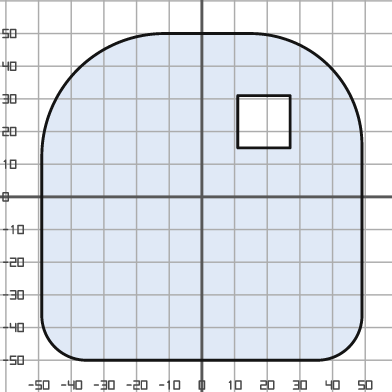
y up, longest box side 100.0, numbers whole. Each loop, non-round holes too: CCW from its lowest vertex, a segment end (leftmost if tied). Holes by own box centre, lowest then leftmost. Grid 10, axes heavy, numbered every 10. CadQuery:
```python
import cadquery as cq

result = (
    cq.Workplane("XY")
    .moveTo(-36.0, -50.0)
    .lineTo(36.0, -50.0)
    .threePointArc((45.0, -46.0), (49.0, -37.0))
    .lineTo(49.0, 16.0)
    .threePointArc((39.0, 40.0), (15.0, 50.0))
    .lineTo(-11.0, 50.0)
    .threePointArc((-38.0, 39.0), (-49.0, 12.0))
    .lineTo(-49.0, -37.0)
    .threePointArc((-45.0, -46.0), (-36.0, -50.0))
    .close()
    .moveTo(11.0, 15.0)
    .lineTo(27.0, 15.0)
    .lineTo(27.0, 31.0)
    .lineTo(11.0, 31.0)
    .close()
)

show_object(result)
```